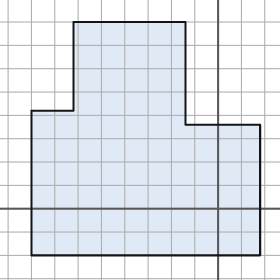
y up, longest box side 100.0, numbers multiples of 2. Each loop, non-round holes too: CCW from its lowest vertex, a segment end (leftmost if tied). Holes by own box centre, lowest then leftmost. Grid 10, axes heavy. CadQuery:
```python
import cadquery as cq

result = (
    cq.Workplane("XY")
    .moveTo(-80.0, -20.0)
    .lineTo(18.0, -20.0)
    .lineTo(18.0, 36.0)
    .lineTo(-14.0, 36.0)
    .lineTo(-14.0, 80.0)
    .lineTo(-62.0, 80.0)
    .lineTo(-62.0, 42.0)
    .lineTo(-80.0, 42.0)
    .close()
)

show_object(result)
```